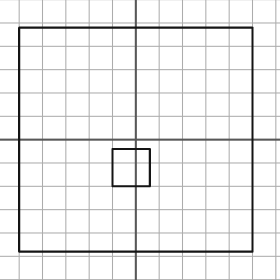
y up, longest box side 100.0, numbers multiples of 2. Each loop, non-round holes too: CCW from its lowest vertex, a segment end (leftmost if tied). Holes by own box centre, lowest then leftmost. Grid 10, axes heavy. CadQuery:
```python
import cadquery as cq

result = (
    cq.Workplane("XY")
    .moveTo(-50.0, -48.0)
    .lineTo(50.0, -48.0)
    .lineTo(50.0, 48.0)
    .lineTo(-50.0, 48.0)
    .close()
    .moveTo(-10.0, -20.0)
    .lineTo(6.0, -20.0)
    .lineTo(6.0, -4.0)
    .lineTo(-10.0, -4.0)
    .close()
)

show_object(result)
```